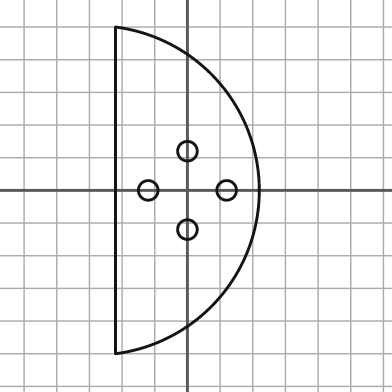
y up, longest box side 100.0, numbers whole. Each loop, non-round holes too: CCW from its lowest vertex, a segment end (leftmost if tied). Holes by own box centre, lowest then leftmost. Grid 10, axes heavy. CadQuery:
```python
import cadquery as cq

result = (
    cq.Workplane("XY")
    .moveTo(-22.0, -50.0)
    .threePointArc((22.0, 0.0), (-22.0, 50.0))
    .close()
    .moveTo(0.0, -12.0)
    .circle(3.0)
    .moveTo(-12.0, 0.0)
    .circle(3.0)
    .moveTo(12.0, 0.0)
    .circle(3.0)
    .moveTo(0.0, 12.0)
    .circle(3.0)
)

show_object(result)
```